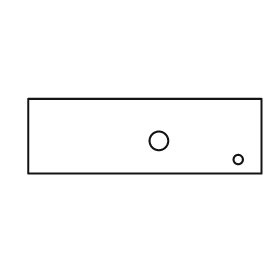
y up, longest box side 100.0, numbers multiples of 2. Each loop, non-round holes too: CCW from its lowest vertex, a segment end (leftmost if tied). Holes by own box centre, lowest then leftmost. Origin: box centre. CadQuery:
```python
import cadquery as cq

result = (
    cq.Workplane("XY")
    .moveTo(-50.0, -16.0)
    .lineTo(50.0, -16.0)
    .lineTo(50.0, 16.0)
    .lineTo(-50.0, 16.0)
    .close()
    .moveTo(40.0, -10.0)
    .circle(2.0)
    .moveTo(6.0, -2.0)
    .circle(4.0)
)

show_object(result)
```